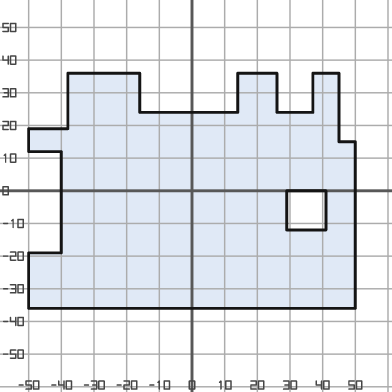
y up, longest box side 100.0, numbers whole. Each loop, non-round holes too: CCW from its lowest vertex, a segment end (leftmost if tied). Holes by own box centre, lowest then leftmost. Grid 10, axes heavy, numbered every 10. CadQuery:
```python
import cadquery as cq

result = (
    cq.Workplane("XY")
    .moveTo(-50.0, -36.0)
    .lineTo(50.0, -36.0)
    .lineTo(50.0, 15.0)
    .lineTo(45.0, 15.0)
    .lineTo(45.0, 36.0)
    .lineTo(37.0, 36.0)
    .lineTo(37.0, 24.0)
    .lineTo(26.0, 24.0)
    .lineTo(26.0, 36.0)
    .lineTo(14.0, 36.0)
    .lineTo(14.0, 24.0)
    .lineTo(-16.0, 24.0)
    .lineTo(-16.0, 36.0)
    .lineTo(-38.0, 36.0)
    .lineTo(-38.0, 19.0)
    .lineTo(-50.0, 19.0)
    .lineTo(-50.0, 12.0)
    .lineTo(-40.0, 12.0)
    .lineTo(-40.0, -19.0)
    .lineTo(-50.0, -19.0)
    .close()
    .moveTo(29.0, -12.0)
    .lineTo(41.0, -12.0)
    .lineTo(41.0, 0.0)
    .lineTo(29.0, 0.0)
    .close()
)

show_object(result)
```